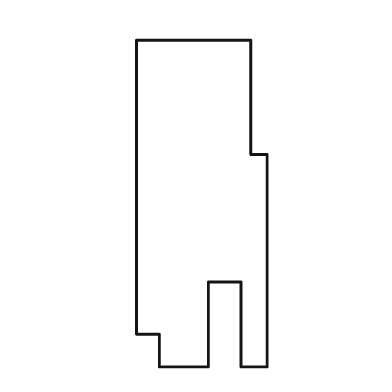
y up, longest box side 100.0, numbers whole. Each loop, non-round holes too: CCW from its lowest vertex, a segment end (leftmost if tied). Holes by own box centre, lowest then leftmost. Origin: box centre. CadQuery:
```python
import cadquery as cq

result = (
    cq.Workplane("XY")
    .moveTo(-13.0, -50.0)
    .lineTo(2.0, -50.0)
    .lineTo(2.0, -24.0)
    .lineTo(12.0, -24.0)
    .lineTo(12.0, -50.0)
    .lineTo(20.0, -50.0)
    .lineTo(20.0, 15.0)
    .lineTo(15.0, 15.0)
    .lineTo(15.0, 50.0)
    .lineTo(-20.0, 50.0)
    .lineTo(-20.0, -40.0)
    .lineTo(-13.0, -40.0)
    .close()
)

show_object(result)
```